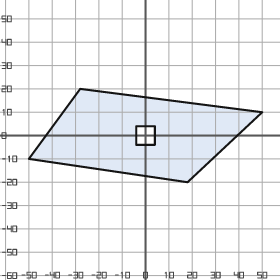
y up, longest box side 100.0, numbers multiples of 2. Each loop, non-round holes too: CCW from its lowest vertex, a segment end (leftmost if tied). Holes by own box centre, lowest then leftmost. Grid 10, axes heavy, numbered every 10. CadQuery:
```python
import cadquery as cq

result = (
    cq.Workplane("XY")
    .moveTo(18.0, -20.0)
    .lineTo(50.0, 10.0)
    .lineTo(-28.0, 20.0)
    .lineTo(-50.0, -10.0)
    .close()
    .moveTo(-4.0, -4.0)
    .lineTo(4.0, -4.0)
    .lineTo(4.0, 4.0)
    .lineTo(-4.0, 4.0)
    .close()
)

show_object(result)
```